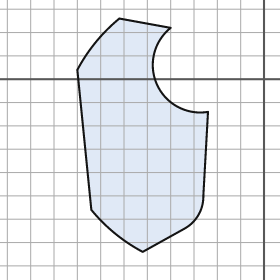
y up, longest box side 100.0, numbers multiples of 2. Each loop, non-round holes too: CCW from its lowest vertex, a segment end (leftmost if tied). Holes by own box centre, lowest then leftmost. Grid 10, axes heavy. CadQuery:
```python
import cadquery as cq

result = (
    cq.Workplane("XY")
    .moveTo(-52.0, -74.0)
    .lineTo(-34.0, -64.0)
    .threePointArc((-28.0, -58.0), (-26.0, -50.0))
    .lineTo(-24.0, -14.0)
    .threePointArc((-46.0, -2.0), (-40.0, 22.0))
    .lineTo(-62.0, 26.0)
    .threePointArc((-72.0, 16.0), (-80.0, 4.0))
    .lineTo(-74.0, -56.0)
    .threePointArc((-64.0, -66.0), (-52.0, -74.0))
    .close()
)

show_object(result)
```